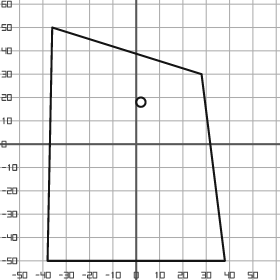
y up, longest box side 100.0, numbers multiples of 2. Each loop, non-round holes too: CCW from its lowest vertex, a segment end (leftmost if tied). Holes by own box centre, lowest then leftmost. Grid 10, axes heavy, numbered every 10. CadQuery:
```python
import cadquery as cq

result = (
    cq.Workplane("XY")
    .moveTo(-38.0, -50.0)
    .lineTo(38.0, -50.0)
    .lineTo(28.0, 30.0)
    .lineTo(-36.0, 50.0)
    .close()
    .moveTo(2.0, 18.0)
    .circle(2.0)
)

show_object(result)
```